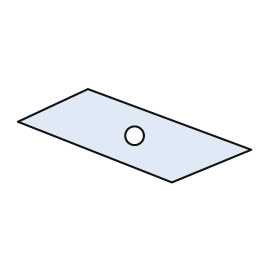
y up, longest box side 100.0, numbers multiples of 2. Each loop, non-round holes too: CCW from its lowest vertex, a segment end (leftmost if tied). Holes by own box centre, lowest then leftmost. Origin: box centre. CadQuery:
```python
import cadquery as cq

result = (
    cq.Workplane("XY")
    .moveTo(16.0, -20.0)
    .lineTo(50.0, -6.0)
    .lineTo(-20.0, 20.0)
    .lineTo(-50.0, 6.0)
    .close()
    .moveTo(0.0, 0.0)
    .circle(4.0)
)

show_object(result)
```